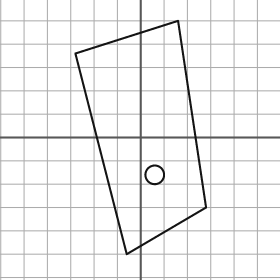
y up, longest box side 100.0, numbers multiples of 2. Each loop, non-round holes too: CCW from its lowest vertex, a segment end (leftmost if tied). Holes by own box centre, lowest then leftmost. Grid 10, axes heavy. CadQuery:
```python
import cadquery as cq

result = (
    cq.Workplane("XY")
    .moveTo(-6.0, -50.0)
    .lineTo(28.0, -30.0)
    .lineTo(16.0, 50.0)
    .lineTo(-28.0, 36.0)
    .close()
    .moveTo(6.0, -16.0)
    .circle(4.0)
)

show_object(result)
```